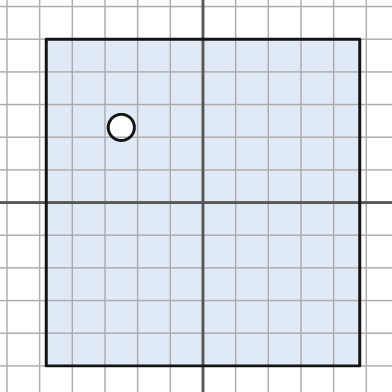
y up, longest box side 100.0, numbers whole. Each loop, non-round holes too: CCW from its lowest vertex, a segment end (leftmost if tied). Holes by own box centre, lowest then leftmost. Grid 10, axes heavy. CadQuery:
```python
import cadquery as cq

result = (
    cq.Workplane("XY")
    .moveTo(-48.0, -50.0)
    .lineTo(48.0, -50.0)
    .lineTo(48.0, 50.0)
    .lineTo(-48.0, 50.0)
    .close()
    .moveTo(-25.0, 23.0)
    .circle(4.0)
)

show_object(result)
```